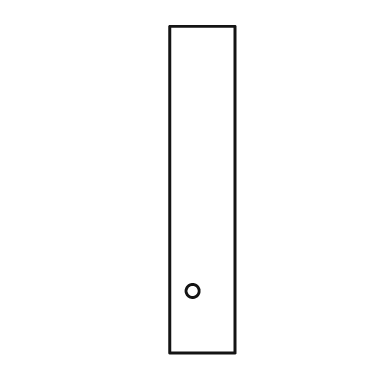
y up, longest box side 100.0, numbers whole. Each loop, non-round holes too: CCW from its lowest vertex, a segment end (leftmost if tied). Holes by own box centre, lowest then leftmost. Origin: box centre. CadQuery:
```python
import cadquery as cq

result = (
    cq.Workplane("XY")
    .moveTo(-10.0, -50.0)
    .lineTo(10.0, -50.0)
    .lineTo(10.0, 50.0)
    .lineTo(-10.0, 50.0)
    .close()
    .moveTo(-3.0, -31.0)
    .circle(2.0)
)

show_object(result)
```